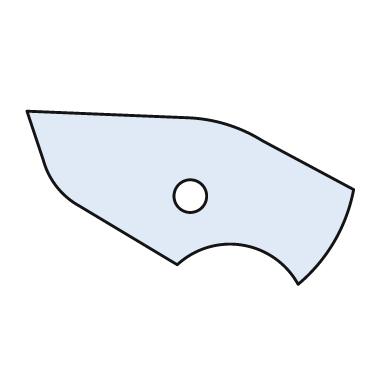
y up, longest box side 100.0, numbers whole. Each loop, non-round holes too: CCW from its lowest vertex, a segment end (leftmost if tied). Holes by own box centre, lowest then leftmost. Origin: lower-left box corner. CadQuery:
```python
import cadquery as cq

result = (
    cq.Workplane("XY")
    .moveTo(83.0, 0.0)
    .threePointArc((94.0, 13.0), (100.0, 29.0))
    .lineTo(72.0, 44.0)
    .threePointArc((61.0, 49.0), (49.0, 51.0))
    .lineTo(0.0, 53.0)
    .lineTo(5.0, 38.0)
    .threePointArc((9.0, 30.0), (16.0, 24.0))
    .lineTo(46.0, 6.0)
    .threePointArc((66.0, 12.0), (83.0, 0.0))
    .close()
    .moveTo(50.0, 27.0)
    .circle(5.0)
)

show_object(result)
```